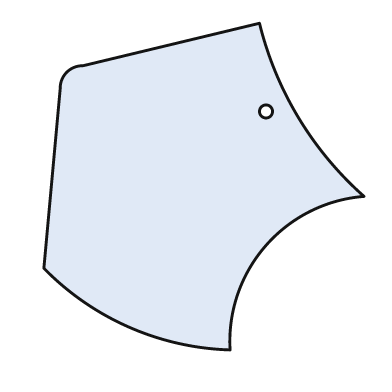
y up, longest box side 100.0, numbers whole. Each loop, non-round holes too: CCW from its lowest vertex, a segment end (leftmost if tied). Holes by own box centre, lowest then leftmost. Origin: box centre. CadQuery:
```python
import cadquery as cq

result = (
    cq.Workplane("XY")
    .moveTo(8.0, -50.0)
    .threePointArc((19.0, -18.0), (49.0, -3.0))
    .threePointArc((29.0, 21.0), (17.0, 50.0))
    .lineTo(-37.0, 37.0)
    .threePointArc((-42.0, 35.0), (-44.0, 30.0))
    .lineTo(-49.0, -25.0)
    .threePointArc((-23.0, -43.0), (8.0, -50.0))
    .close()
    .moveTo(19.0, 23.0)
    .circle(2.0)
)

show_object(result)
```